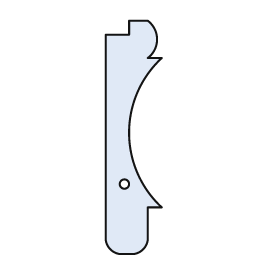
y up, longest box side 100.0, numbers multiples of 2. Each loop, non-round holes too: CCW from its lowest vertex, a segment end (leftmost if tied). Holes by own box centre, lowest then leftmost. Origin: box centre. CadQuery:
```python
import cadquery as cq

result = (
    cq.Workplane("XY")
    .moveTo(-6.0, -50.0)
    .lineTo(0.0, -50.0)
    .threePointArc((4.0, -48.0), (6.0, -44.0))
    .lineTo(6.0, -30.0)
    .lineTo(12.0, -30.0)
    .threePointArc((-2.0, 2.0), (12.0, 34.0))
    .lineTo(6.0, 34.0)
    .threePointArc((10.0, 42.0), (6.0, 50.0))
    .lineTo(-2.0, 50.0)
    .lineTo(-2.0, 44.0)
    .lineTo(-12.0, 44.0)
    .lineTo(-12.0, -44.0)
    .threePointArc((-10.0, -48.0), (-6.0, -50.0))
    .close()
    .moveTo(-4.0, -20.0)
    .circle(2.0)
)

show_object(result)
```